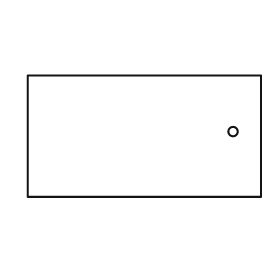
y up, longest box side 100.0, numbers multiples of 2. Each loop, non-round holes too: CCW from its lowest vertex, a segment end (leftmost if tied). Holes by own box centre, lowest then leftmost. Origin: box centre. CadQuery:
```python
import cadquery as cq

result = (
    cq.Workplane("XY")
    .moveTo(-50.0, -26.0)
    .lineTo(50.0, -26.0)
    .lineTo(50.0, 26.0)
    .lineTo(-50.0, 26.0)
    .close()
    .moveTo(38.0, 2.0)
    .circle(2.0)
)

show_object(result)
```